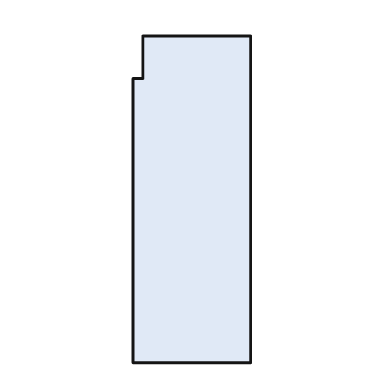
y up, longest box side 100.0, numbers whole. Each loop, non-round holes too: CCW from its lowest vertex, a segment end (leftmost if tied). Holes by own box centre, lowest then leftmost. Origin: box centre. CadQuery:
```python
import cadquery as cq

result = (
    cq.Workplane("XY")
    .moveTo(-18.0, -50.0)
    .lineTo(18.0, -50.0)
    .lineTo(18.0, 50.0)
    .lineTo(-15.0, 50.0)
    .lineTo(-15.0, 37.0)
    .lineTo(-18.0, 37.0)
    .close()
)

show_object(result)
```